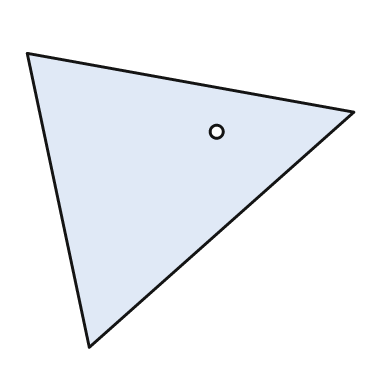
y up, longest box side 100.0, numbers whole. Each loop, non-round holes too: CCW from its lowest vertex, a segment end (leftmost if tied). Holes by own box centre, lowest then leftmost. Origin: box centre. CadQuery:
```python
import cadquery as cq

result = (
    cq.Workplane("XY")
    .moveTo(-31.0, -45.0)
    .lineTo(50.0, 27.0)
    .lineTo(-50.0, 45.0)
    .close()
    .moveTo(8.0, 21.0)
    .circle(2.0)
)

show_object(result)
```